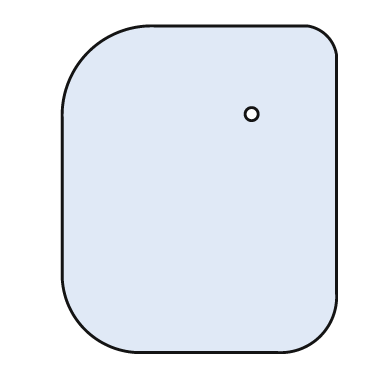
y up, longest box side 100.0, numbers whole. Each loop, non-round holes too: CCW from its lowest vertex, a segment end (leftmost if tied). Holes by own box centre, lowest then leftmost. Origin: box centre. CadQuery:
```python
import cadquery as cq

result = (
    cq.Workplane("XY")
    .moveTo(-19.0, -50.0)
    .lineTo(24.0, -50.0)
    .threePointArc((37.0, -45.0), (42.0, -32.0))
    .lineTo(42.0, 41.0)
    .threePointArc((39.0, 47.0), (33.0, 50.0))
    .lineTo(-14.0, 50.0)
    .threePointArc((-34.0, 42.0), (-42.0, 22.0))
    .lineTo(-42.0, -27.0)
    .threePointArc((-35.0, -43.0), (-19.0, -50.0))
    .close()
    .moveTo(16.0, 23.0)
    .circle(2.0)
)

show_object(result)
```